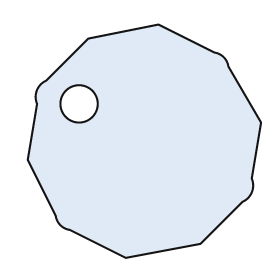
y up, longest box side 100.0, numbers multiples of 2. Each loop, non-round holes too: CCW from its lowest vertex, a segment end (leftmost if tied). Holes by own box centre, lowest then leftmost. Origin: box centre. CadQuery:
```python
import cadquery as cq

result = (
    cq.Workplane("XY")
    .moveTo(-8.0, -50.0)
    .lineTo(24.0, -44.0)
    .lineTo(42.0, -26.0)
    .threePointArc((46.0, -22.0), (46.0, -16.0))
    .lineTo(50.0, 8.0)
    .lineTo(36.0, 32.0)
    .threePointArc((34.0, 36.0), (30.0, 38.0))
    .lineTo(6.0, 50.0)
    .lineTo(-24.0, 44.0)
    .lineTo(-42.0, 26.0)
    .threePointArc((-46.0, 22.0), (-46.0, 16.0))
    .lineTo(-50.0, -8.0)
    .lineTo(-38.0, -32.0)
    .threePointArc((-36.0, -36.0), (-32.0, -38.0))
    .close()
    .moveTo(-28.0, 16.0)
    .circle(8.0)
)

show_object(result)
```